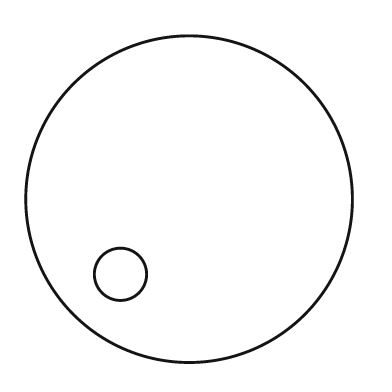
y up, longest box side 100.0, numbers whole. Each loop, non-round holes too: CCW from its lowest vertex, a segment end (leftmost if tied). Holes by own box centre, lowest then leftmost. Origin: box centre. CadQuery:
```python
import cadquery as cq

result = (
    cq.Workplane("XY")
    .moveTo(0.0, 0.0)
    .circle(50.0)
    .moveTo(-21.0, -23.0)
    .circle(8.0)
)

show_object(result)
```